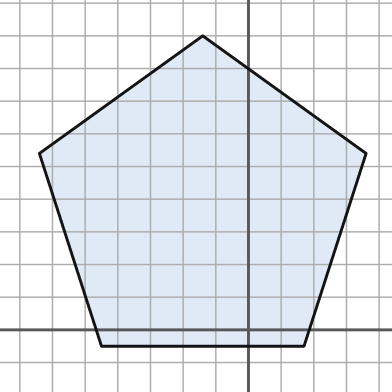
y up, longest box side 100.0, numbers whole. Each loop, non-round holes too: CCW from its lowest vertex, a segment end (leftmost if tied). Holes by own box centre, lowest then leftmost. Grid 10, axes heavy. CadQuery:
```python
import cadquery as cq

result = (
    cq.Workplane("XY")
    .moveTo(-45.0, -5.0)
    .lineTo(17.0, -5.0)
    .lineTo(36.0, 54.0)
    .lineTo(-14.0, 90.0)
    .lineTo(-64.0, 54.0)
    .close()
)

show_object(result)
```